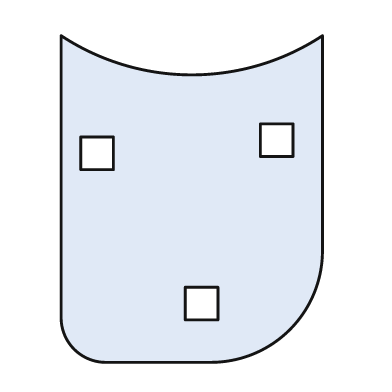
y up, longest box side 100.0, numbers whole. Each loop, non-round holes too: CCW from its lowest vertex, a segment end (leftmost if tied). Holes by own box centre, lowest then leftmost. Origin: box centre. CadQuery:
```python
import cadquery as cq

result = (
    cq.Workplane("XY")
    .moveTo(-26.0, -50.0)
    .lineTo(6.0, -50.0)
    .threePointArc((30.0, -40.0), (40.0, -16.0))
    .lineTo(40.0, 50.0)
    .threePointArc((0.0, 38.0), (-40.0, 50.0))
    .lineTo(-40.0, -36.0)
    .threePointArc((-36.0, -46.0), (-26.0, -50.0))
    .close()
    .moveTo(-2.0, -37.0)
    .lineTo(8.0, -37.0)
    .lineTo(8.0, -27.0)
    .lineTo(-2.0, -27.0)
    .close()
    .moveTo(-34.0, 9.0)
    .lineTo(-24.0, 9.0)
    .lineTo(-24.0, 19.0)
    .lineTo(-34.0, 19.0)
    .close()
    .moveTo(21.0, 13.0)
    .lineTo(31.0, 13.0)
    .lineTo(31.0, 23.0)
    .lineTo(21.0, 23.0)
    .close()
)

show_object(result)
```